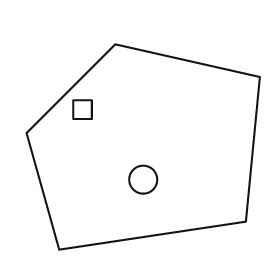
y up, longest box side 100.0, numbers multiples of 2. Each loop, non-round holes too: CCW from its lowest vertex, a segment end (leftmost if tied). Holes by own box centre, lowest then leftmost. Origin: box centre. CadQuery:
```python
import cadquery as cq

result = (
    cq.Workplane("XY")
    .moveTo(-36.0, -44.0)
    .lineTo(44.0, -32.0)
    .lineTo(50.0, 30.0)
    .lineTo(-12.0, 44.0)
    .lineTo(-50.0, 6.0)
    .close()
    .moveTo(0.0, -14.0)
    .circle(6.0)
    .moveTo(-30.0, 12.0)
    .lineTo(-22.0, 12.0)
    .lineTo(-22.0, 20.0)
    .lineTo(-30.0, 20.0)
    .close()
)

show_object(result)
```